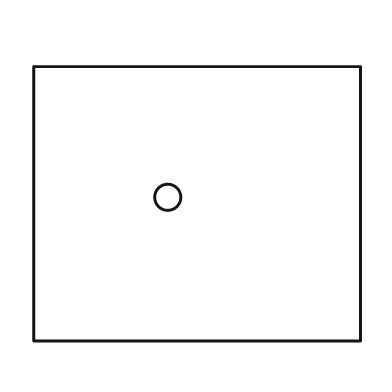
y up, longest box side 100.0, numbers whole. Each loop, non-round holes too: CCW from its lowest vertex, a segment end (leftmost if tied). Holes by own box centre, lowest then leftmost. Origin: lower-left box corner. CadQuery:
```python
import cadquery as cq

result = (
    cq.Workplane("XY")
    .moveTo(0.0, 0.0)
    .lineTo(100.0, 0.0)
    .lineTo(100.0, 84.0)
    .lineTo(0.0, 84.0)
    .close()
    .moveTo(41.0, 44.0)
    .circle(4.0)
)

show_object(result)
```